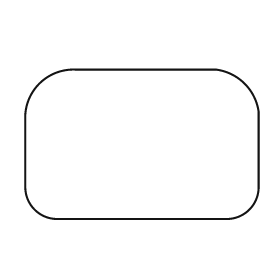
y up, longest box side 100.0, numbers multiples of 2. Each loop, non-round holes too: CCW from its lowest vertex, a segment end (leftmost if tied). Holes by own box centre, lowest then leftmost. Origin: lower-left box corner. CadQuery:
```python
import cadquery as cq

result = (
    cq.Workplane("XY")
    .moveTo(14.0, 0.0)
    .lineTo(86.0, 0.0)
    .threePointArc((96.0, 4.0), (100.0, 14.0))
    .lineTo(100.0, 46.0)
    .threePointArc((94.0, 58.0), (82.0, 64.0))
    .lineTo(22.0, 64.0)
    .threePointArc((6.0, 58.0), (0.0, 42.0))
    .lineTo(0.0, 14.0)
    .threePointArc((4.0, 4.0), (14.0, 0.0))
    .close()
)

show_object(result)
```